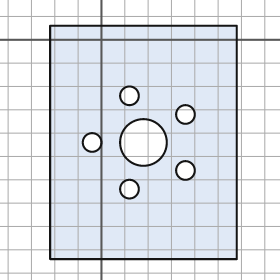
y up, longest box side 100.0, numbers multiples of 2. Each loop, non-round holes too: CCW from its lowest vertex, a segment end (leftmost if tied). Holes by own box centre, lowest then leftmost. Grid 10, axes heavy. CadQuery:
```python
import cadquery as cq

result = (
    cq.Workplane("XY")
    .moveTo(-22.0, -94.0)
    .lineTo(58.0, -94.0)
    .lineTo(58.0, 6.0)
    .lineTo(-22.0, 6.0)
    .close()
    .moveTo(12.0, -64.0)
    .circle(4.0)
    .moveTo(36.0, -56.0)
    .circle(4.0)
    .moveTo(-4.0, -44.0)
    .circle(4.0)
    .moveTo(18.0, -44.0)
    .circle(10.0)
    .moveTo(36.0, -32.0)
    .circle(4.0)
    .moveTo(12.0, -24.0)
    .circle(4.0)
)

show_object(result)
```